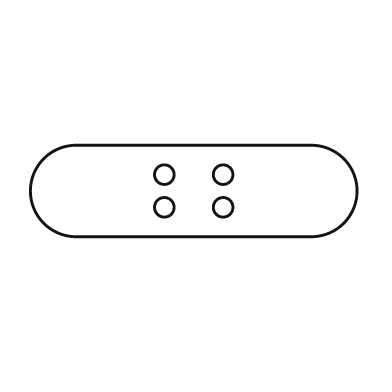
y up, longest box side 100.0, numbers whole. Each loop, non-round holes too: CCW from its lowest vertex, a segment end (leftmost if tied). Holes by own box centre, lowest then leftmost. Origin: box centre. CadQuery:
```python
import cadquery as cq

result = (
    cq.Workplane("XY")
    .moveTo(-36.0, -14.0)
    .lineTo(36.0, -14.0)
    .threePointArc((50.0, 0.0), (36.0, 14.0))
    .lineTo(-36.0, 14.0)
    .threePointArc((-50.0, 0.0), (-36.0, -14.0))
    .close()
    .moveTo(-9.0, -5.0)
    .circle(3.0)
    .moveTo(9.0, -5.0)
    .circle(3.0)
    .moveTo(-9.0, 5.0)
    .circle(3.0)
    .moveTo(9.0, 5.0)
    .circle(3.0)
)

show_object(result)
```